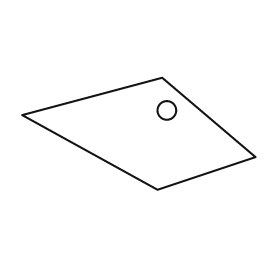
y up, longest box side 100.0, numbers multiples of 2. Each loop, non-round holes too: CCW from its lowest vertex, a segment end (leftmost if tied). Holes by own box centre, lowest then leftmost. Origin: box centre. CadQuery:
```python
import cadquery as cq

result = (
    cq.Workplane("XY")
    .moveTo(8.0, -24.0)
    .lineTo(50.0, -10.0)
    .lineTo(10.0, 24.0)
    .lineTo(-50.0, 8.0)
    .close()
    .moveTo(12.0, 10.0)
    .circle(4.0)
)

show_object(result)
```